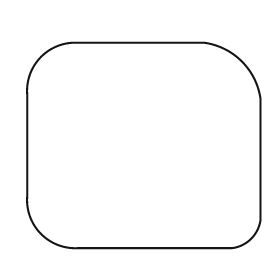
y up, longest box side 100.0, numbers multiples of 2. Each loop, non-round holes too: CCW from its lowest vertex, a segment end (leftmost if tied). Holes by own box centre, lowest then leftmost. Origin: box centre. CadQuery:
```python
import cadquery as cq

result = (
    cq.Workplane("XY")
    .moveTo(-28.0, -44.0)
    .lineTo(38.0, -44.0)
    .threePointArc((46.0, -40.0), (50.0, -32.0))
    .lineTo(50.0, 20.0)
    .threePointArc((42.0, 36.0), (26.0, 44.0))
    .lineTo(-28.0, 44.0)
    .threePointArc((-44.0, 38.0), (-50.0, 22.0))
    .lineTo(-50.0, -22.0)
    .threePointArc((-44.0, -38.0), (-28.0, -44.0))
    .close()
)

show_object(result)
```